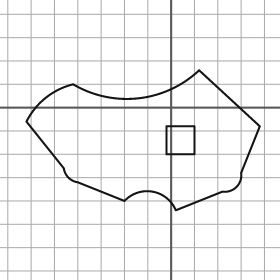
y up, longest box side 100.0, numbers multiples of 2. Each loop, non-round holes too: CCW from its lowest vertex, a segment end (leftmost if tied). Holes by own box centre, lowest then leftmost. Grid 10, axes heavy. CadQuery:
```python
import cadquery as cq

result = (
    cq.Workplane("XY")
    .moveTo(2.0, -44.0)
    .lineTo(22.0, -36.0)
    .threePointArc((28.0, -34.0), (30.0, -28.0))
    .lineTo(38.0, -8.0)
    .lineTo(12.0, 16.0)
    .threePointArc((-14.0, 4.0), (-42.0, 10.0))
    .threePointArc((-54.0, 4.0), (-62.0, -6.0))
    .lineTo(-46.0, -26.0)
    .threePointArc((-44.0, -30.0), (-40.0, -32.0))
    .lineTo(-20.0, -40.0)
    .threePointArc((-8.0, -36.0), (2.0, -44.0))
    .close()
    .moveTo(-2.0, -20.0)
    .lineTo(10.0, -20.0)
    .lineTo(10.0, -8.0)
    .lineTo(-2.0, -8.0)
    .close()
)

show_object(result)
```